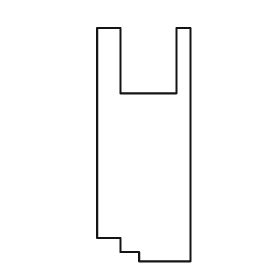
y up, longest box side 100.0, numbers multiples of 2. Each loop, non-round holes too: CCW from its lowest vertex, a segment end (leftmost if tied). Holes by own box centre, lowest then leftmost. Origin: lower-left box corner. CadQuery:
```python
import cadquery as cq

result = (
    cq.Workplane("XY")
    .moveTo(18.0, 0.0)
    .lineTo(40.0, 0.0)
    .lineTo(40.0, 100.0)
    .lineTo(34.0, 100.0)
    .lineTo(34.0, 72.0)
    .lineTo(10.0, 72.0)
    .lineTo(10.0, 100.0)
    .lineTo(0.0, 100.0)
    .lineTo(0.0, 10.0)
    .lineTo(10.0, 10.0)
    .lineTo(10.0, 4.0)
    .lineTo(18.0, 4.0)
    .close()
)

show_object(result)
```